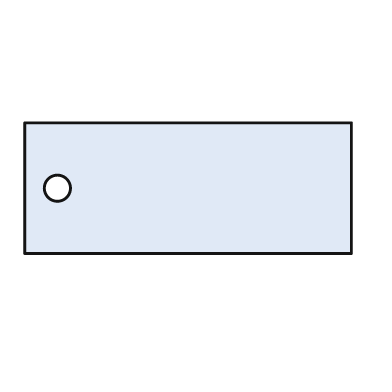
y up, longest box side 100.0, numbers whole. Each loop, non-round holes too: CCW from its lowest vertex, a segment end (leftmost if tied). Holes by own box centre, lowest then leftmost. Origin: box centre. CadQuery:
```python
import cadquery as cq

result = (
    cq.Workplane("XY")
    .moveTo(-50.0, -20.0)
    .lineTo(50.0, -20.0)
    .lineTo(50.0, 20.0)
    .lineTo(-50.0, 20.0)
    .close()
    .moveTo(-40.0, 0.0)
    .circle(4.0)
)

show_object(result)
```